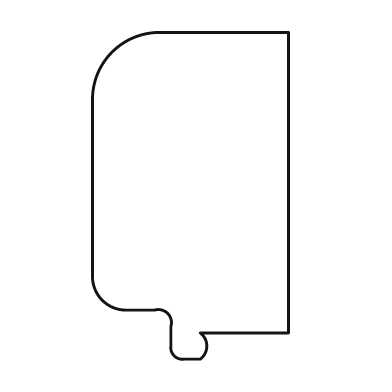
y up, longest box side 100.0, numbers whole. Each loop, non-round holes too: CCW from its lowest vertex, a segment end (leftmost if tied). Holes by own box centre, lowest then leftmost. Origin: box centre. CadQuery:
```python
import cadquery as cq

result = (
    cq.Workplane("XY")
    .moveTo(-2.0, -50.0)
    .lineTo(3.0, -50.0)
    .threePointArc((5.0, -46.0), (3.0, -42.0))
    .lineTo(30.0, -42.0)
    .lineTo(30.0, 50.0)
    .lineTo(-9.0, 50.0)
    .threePointArc((-24.0, 44.0), (-30.0, 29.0))
    .lineTo(-30.0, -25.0)
    .threePointArc((-27.0, -32.0), (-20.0, -35.0))
    .lineTo(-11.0, -35.0)
    .threePointArc((-7.0, -36.0), (-6.0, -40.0))
    .lineTo(-6.0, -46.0)
    .threePointArc((-5.0, -49.0), (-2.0, -50.0))
    .close()
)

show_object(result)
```